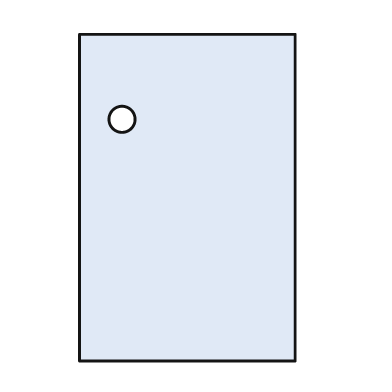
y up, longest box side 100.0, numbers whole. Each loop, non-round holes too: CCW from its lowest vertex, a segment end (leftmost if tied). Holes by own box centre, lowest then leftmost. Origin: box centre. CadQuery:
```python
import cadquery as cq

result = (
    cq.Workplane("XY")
    .moveTo(-33.0, -50.0)
    .lineTo(33.0, -50.0)
    .lineTo(33.0, 50.0)
    .lineTo(-33.0, 50.0)
    .close()
    .moveTo(-20.0, 24.0)
    .circle(4.0)
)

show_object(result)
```